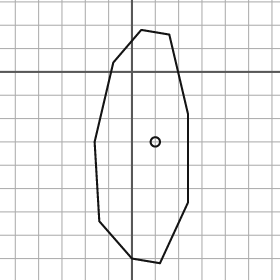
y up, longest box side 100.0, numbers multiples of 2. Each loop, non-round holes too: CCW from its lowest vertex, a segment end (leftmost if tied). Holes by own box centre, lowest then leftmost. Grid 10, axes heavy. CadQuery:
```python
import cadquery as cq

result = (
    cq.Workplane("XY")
    .moveTo(12.0, -82.0)
    .lineTo(24.0, -56.0)
    .lineTo(24.0, -18.0)
    .lineTo(16.0, 16.0)
    .lineTo(4.0, 18.0)
    .lineTo(-8.0, 4.0)
    .lineTo(-16.0, -30.0)
    .lineTo(-14.0, -64.0)
    .lineTo(0.0, -80.0)
    .close()
    .moveTo(10.0, -30.0)
    .circle(2.0)
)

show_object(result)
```